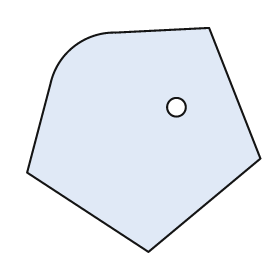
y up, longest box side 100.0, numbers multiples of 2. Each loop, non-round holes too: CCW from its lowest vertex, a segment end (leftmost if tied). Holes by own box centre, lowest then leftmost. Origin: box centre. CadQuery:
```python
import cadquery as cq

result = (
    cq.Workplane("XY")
    .moveTo(2.0, -48.0)
    .lineTo(50.0, -8.0)
    .lineTo(28.0, 48.0)
    .lineTo(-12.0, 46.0)
    .threePointArc((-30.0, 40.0), (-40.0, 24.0))
    .lineTo(-50.0, -14.0)
    .close()
    .moveTo(14.0, 14.0)
    .circle(4.0)
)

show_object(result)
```